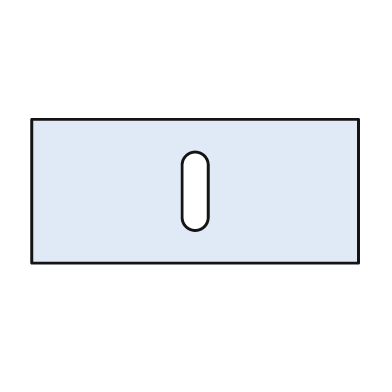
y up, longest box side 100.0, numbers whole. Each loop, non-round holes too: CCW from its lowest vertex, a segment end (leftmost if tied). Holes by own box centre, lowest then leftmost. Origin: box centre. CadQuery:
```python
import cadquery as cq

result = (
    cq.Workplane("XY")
    .moveTo(-50.0, -22.0)
    .lineTo(50.0, -22.0)
    .lineTo(50.0, 22.0)
    .lineTo(-50.0, 22.0)
    .close()
    .moveTo(-4.0, -8.0)
    .threePointArc((0.0, -12.0), (4.0, -8.0))
    .lineTo(4.0, 8.0)
    .threePointArc((0.0, 12.0), (-4.0, 8.0))
    .close()
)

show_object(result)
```